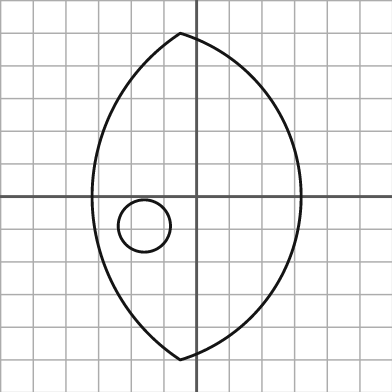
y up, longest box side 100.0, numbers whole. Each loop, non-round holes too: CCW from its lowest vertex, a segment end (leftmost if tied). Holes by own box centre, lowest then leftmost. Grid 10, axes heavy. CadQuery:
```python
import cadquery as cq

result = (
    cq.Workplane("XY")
    .moveTo(-5.0, -50.0)
    .threePointArc((32.0, 0.0), (-5.0, 50.0))
    .threePointArc((-32.0, 0.0), (-5.0, -50.0))
    .close()
    .moveTo(-16.0, -9.0)
    .circle(8.0)
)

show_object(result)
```